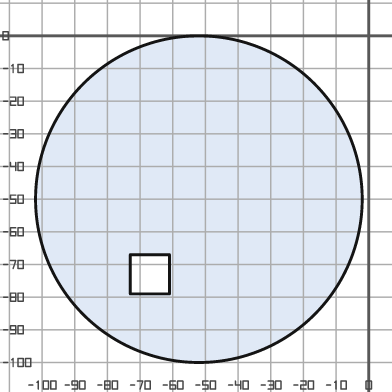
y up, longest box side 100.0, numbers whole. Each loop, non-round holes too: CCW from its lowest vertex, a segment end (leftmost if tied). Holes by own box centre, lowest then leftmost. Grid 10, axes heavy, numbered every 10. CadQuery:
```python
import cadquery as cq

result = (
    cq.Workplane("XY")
    .moveTo(-52.0, -50.0)
    .circle(50.0)
    .moveTo(-73.0, -79.0)
    .lineTo(-61.0, -79.0)
    .lineTo(-61.0, -67.0)
    .lineTo(-73.0, -67.0)
    .close()
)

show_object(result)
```